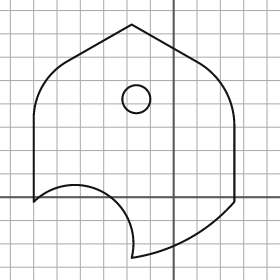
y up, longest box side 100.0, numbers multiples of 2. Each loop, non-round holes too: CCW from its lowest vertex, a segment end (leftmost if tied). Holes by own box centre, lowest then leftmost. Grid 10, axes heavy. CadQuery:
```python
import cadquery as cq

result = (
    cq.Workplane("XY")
    .moveTo(-18.0, -26.0)
    .threePointArc((6.0, -18.0), (26.0, -2.0))
    .lineTo(26.0, 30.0)
    .threePointArc((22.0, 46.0), (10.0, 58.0))
    .lineTo(-18.0, 74.0)
    .lineTo(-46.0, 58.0)
    .threePointArc((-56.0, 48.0), (-60.0, 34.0))
    .lineTo(-60.0, -2.0)
    .threePointArc((-30.0, 2.0), (-18.0, -26.0))
    .close()
    .moveTo(-16.0, 42.0)
    .circle(6.0)
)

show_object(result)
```